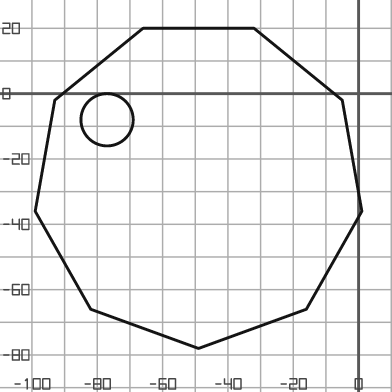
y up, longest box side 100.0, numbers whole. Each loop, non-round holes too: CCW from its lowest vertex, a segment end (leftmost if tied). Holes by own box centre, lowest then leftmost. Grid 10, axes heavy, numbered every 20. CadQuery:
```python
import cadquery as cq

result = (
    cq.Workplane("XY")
    .moveTo(-49.0, -78.0)
    .lineTo(-16.0, -66.0)
    .lineTo(1.0, -36.0)
    .lineTo(-5.0, -2.0)
    .lineTo(-32.0, 20.0)
    .lineTo(-66.0, 20.0)
    .lineTo(-93.0, -2.0)
    .lineTo(-99.0, -36.0)
    .lineTo(-82.0, -66.0)
    .close()
    .moveTo(-77.0, -8.0)
    .circle(8.0)
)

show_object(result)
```